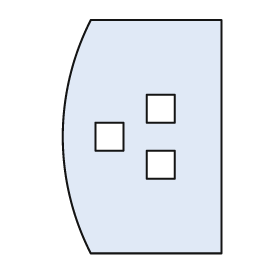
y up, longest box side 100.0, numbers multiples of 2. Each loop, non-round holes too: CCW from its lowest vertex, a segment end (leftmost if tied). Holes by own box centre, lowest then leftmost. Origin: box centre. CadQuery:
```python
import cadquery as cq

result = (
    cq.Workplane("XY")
    .moveTo(-22.0, -50.0)
    .lineTo(34.0, -50.0)
    .lineTo(34.0, 50.0)
    .lineTo(-22.0, 50.0)
    .threePointArc((-34.0, 0.0), (-22.0, -50.0))
    .close()
    .moveTo(2.0, -18.0)
    .lineTo(14.0, -18.0)
    .lineTo(14.0, -6.0)
    .lineTo(2.0, -6.0)
    .close()
    .moveTo(-20.0, -6.0)
    .lineTo(-8.0, -6.0)
    .lineTo(-8.0, 6.0)
    .lineTo(-20.0, 6.0)
    .close()
    .moveTo(2.0, 6.0)
    .lineTo(14.0, 6.0)
    .lineTo(14.0, 18.0)
    .lineTo(2.0, 18.0)
    .close()
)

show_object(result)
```